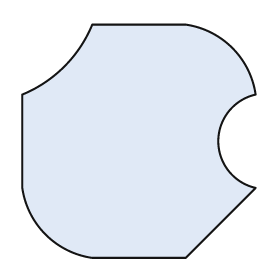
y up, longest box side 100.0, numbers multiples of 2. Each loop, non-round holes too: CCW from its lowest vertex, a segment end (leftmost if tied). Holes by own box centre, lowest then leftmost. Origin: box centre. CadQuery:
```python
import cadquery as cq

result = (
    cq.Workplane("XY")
    .moveTo(-20.0, -50.0)
    .lineTo(20.0, -50.0)
    .lineTo(50.0, -20.0)
    .threePointArc((34.0, 0.0), (50.0, 20.0))
    .threePointArc((40.0, 40.0), (20.0, 50.0))
    .lineTo(-20.0, 50.0)
    .threePointArc((-32.0, 32.0), (-50.0, 20.0))
    .lineTo(-50.0, -20.0)
    .threePointArc((-40.0, -40.0), (-20.0, -50.0))
    .close()
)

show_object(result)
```